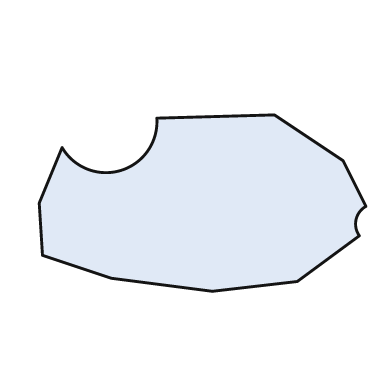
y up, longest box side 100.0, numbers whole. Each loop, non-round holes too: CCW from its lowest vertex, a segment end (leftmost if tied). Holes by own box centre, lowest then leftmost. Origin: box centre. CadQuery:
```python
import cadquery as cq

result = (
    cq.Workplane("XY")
    .moveTo(3.0, -27.0)
    .lineTo(29.0, -24.0)
    .lineTo(48.0, -10.0)
    .threePointArc((47.0, -5.0), (50.0, -1.0))
    .lineTo(43.0, 13.0)
    .lineTo(22.0, 27.0)
    .lineTo(-14.0, 26.0)
    .threePointArc((-25.0, 10.0), (-43.0, 17.0))
    .lineTo(-50.0, 0.0)
    .lineTo(-49.0, -16.0)
    .lineTo(-28.0, -23.0)
    .close()
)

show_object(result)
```